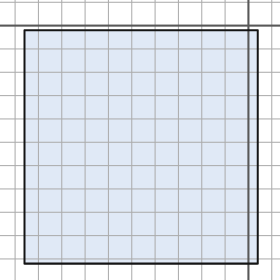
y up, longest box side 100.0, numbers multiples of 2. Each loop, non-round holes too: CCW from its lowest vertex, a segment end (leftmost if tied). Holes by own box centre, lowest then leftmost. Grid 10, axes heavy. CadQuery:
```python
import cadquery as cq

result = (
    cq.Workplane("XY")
    .moveTo(-96.0, -102.0)
    .lineTo(4.0, -102.0)
    .lineTo(4.0, -2.0)
    .lineTo(-96.0, -2.0)
    .close()
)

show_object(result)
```